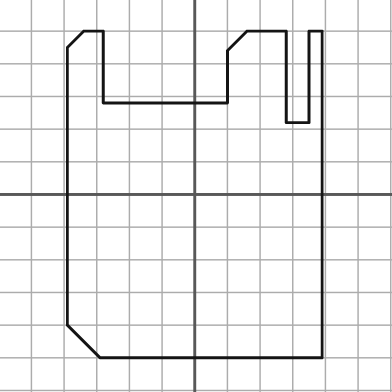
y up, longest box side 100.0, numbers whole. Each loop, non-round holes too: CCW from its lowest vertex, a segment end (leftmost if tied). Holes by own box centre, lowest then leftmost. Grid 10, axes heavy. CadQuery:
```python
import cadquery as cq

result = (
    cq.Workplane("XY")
    .moveTo(-29.0, -50.0)
    .lineTo(39.0, -50.0)
    .lineTo(39.0, 50.0)
    .lineTo(35.0, 50.0)
    .lineTo(35.0, 22.0)
    .lineTo(28.0, 22.0)
    .lineTo(28.0, 50.0)
    .lineTo(16.0, 50.0)
    .lineTo(10.0, 44.0)
    .lineTo(10.0, 28.0)
    .lineTo(-28.0, 28.0)
    .lineTo(-28.0, 50.0)
    .lineTo(-34.0, 50.0)
    .lineTo(-39.0, 45.0)
    .lineTo(-39.0, -40.0)
    .close()
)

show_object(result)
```